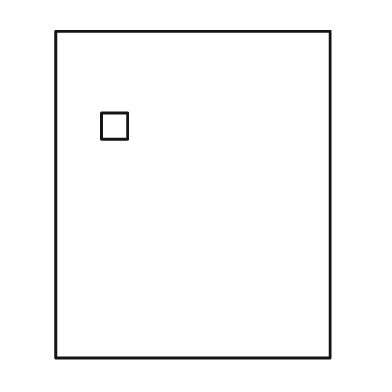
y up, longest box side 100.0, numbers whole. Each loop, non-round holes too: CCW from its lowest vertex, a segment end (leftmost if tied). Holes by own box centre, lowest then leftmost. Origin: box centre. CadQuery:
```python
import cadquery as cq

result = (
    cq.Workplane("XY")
    .moveTo(-42.0, -50.0)
    .lineTo(42.0, -50.0)
    .lineTo(42.0, 50.0)
    .lineTo(-42.0, 50.0)
    .close()
    .moveTo(-28.0, 17.0)
    .lineTo(-20.0, 17.0)
    .lineTo(-20.0, 25.0)
    .lineTo(-28.0, 25.0)
    .close()
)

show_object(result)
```